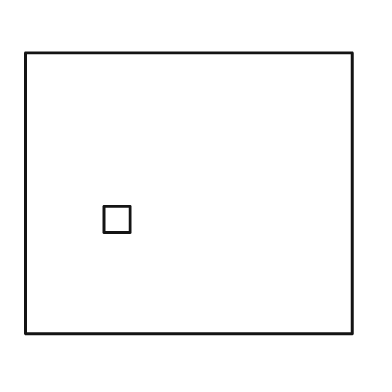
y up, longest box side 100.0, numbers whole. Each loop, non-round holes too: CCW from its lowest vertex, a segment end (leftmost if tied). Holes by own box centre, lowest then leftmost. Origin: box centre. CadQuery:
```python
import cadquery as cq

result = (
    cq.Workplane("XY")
    .moveTo(-50.0, -43.0)
    .lineTo(50.0, -43.0)
    .lineTo(50.0, 43.0)
    .lineTo(-50.0, 43.0)
    .close()
    .moveTo(-26.0, -12.0)
    .lineTo(-18.0, -12.0)
    .lineTo(-18.0, -4.0)
    .lineTo(-26.0, -4.0)
    .close()
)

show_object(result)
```